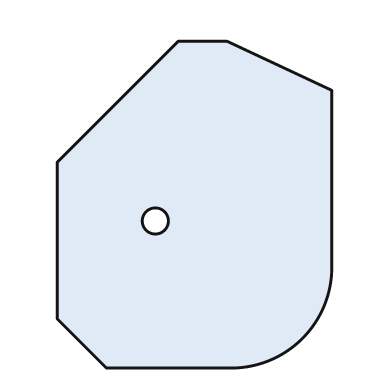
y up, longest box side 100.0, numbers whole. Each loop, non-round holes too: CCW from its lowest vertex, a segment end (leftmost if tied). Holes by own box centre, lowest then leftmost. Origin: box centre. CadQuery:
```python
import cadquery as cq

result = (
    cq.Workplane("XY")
    .moveTo(-27.0, -50.0)
    .lineTo(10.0, -50.0)
    .threePointArc((33.0, -41.0), (42.0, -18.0))
    .lineTo(42.0, 35.0)
    .lineTo(10.0, 50.0)
    .lineTo(-5.0, 50.0)
    .lineTo(-42.0, 13.0)
    .lineTo(-42.0, -35.0)
    .close()
    .moveTo(-12.0, -5.0)
    .circle(4.0)
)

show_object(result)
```